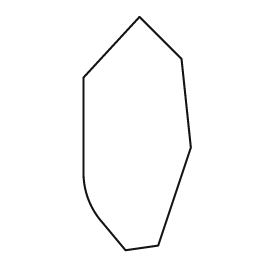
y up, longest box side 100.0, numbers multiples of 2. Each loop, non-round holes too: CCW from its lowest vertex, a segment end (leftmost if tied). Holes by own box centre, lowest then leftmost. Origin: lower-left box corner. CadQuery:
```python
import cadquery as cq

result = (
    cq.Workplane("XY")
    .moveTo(18.0, 0.0)
    .lineTo(32.0, 2.0)
    .lineTo(46.0, 44.0)
    .lineTo(42.0, 82.0)
    .lineTo(24.0, 100.0)
    .lineTo(0.0, 74.0)
    .lineTo(0.0, 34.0)
    .threePointArc((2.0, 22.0), (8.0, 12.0))
    .close()
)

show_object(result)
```